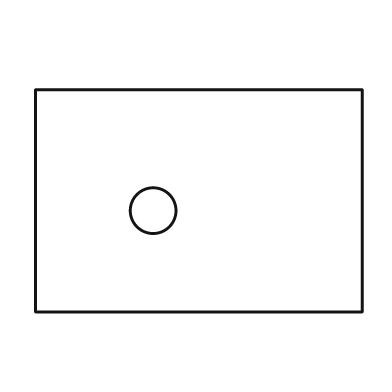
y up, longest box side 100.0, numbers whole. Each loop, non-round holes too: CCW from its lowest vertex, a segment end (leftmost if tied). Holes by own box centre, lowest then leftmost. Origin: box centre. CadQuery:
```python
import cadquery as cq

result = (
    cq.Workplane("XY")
    .moveTo(-50.0, -34.0)
    .lineTo(50.0, -34.0)
    .lineTo(50.0, 34.0)
    .lineTo(-50.0, 34.0)
    .close()
    .moveTo(-14.0, -3.0)
    .circle(7.0)
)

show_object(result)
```